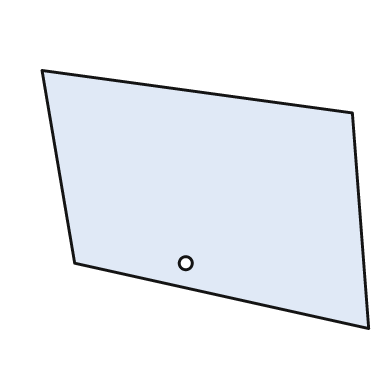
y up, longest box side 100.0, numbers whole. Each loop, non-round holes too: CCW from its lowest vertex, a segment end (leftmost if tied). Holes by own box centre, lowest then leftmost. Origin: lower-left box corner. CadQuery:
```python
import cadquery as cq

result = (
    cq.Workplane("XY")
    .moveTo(100.0, 0.0)
    .lineTo(95.0, 66.0)
    .lineTo(0.0, 79.0)
    .lineTo(10.0, 20.0)
    .close()
    .moveTo(44.0, 20.0)
    .circle(2.0)
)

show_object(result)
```